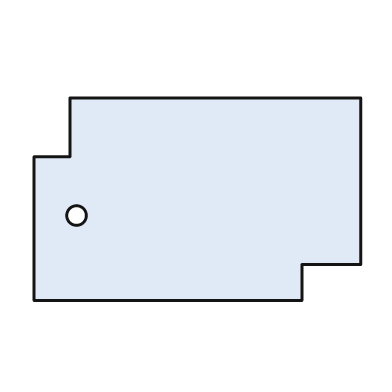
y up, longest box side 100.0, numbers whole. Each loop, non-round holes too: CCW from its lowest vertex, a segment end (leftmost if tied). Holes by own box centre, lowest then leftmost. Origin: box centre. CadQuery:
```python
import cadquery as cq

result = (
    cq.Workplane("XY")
    .moveTo(-50.0, -31.0)
    .lineTo(32.0, -31.0)
    .lineTo(32.0, -20.0)
    .lineTo(50.0, -20.0)
    .lineTo(50.0, 31.0)
    .lineTo(-39.0, 31.0)
    .lineTo(-39.0, 13.0)
    .lineTo(-50.0, 13.0)
    .close()
    .moveTo(-37.0, -5.0)
    .circle(3.0)
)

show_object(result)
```